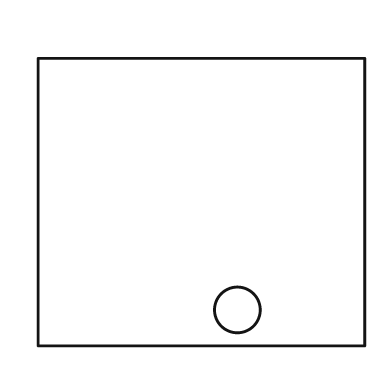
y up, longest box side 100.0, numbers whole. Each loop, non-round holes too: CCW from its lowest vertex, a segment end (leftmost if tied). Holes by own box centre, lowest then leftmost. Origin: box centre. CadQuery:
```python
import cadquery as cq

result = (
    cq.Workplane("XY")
    .moveTo(-50.0, -44.0)
    .lineTo(50.0, -44.0)
    .lineTo(50.0, 44.0)
    .lineTo(-50.0, 44.0)
    .close()
    .moveTo(11.0, -33.0)
    .circle(7.0)
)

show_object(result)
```